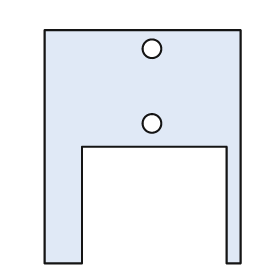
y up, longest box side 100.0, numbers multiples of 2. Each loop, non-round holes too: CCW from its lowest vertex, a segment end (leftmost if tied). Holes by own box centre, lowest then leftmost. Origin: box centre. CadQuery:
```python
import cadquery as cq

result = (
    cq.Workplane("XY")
    .moveTo(-42.0, -50.0)
    .lineTo(-26.0, -50.0)
    .lineTo(-26.0, 0.0)
    .lineTo(36.0, 0.0)
    .lineTo(36.0, -50.0)
    .lineTo(42.0, -50.0)
    .lineTo(42.0, 50.0)
    .lineTo(-42.0, 50.0)
    .close()
    .moveTo(4.0, 10.0)
    .circle(4.0)
    .moveTo(4.0, 42.0)
    .circle(4.0)
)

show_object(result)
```